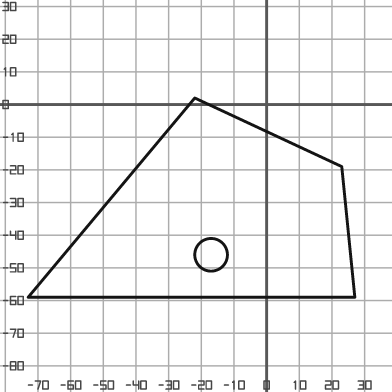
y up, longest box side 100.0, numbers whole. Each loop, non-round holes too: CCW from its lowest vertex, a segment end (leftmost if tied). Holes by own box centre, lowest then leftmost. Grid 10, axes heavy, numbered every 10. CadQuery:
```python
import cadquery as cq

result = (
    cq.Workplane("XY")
    .moveTo(-73.0, -59.0)
    .lineTo(27.0, -59.0)
    .lineTo(23.0, -19.0)
    .lineTo(-22.0, 2.0)
    .close()
    .moveTo(-17.0, -46.0)
    .circle(5.0)
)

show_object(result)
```